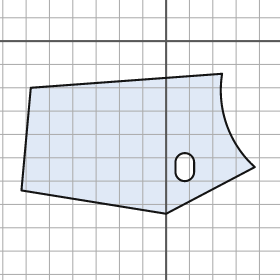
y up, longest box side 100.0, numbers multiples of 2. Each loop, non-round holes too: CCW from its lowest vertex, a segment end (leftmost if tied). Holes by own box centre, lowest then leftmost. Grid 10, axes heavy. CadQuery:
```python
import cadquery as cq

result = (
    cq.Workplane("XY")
    .moveTo(0.0, -74.0)
    .lineTo(38.0, -54.0)
    .threePointArc((26.0, -36.0), (24.0, -14.0))
    .lineTo(-58.0, -20.0)
    .lineTo(-62.0, -64.0)
    .close()
    .moveTo(4.0, -56.0)
    .threePointArc((8.0, -60.0), (12.0, -56.0))
    .lineTo(12.0, -52.0)
    .threePointArc((8.0, -48.0), (4.0, -52.0))
    .close()
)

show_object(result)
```